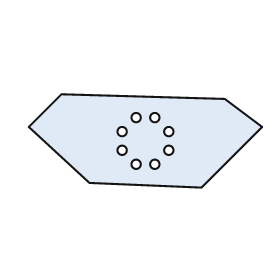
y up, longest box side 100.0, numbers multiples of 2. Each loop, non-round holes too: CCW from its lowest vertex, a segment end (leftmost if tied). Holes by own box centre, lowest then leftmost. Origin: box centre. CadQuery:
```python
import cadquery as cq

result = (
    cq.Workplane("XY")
    .moveTo(24.0, -20.0)
    .lineTo(50.0, 6.0)
    .lineTo(34.0, 18.0)
    .lineTo(-36.0, 20.0)
    .lineTo(-50.0, 6.0)
    .lineTo(-24.0, -18.0)
    .close()
    .moveTo(-4.0, -10.0)
    .circle(2.0)
    .moveTo(4.0, -10.0)
    .circle(2.0)
    .moveTo(-10.0, -4.0)
    .circle(2.0)
    .moveTo(10.0, -4.0)
    .circle(2.0)
    .moveTo(-10.0, 4.0)
    .circle(2.0)
    .moveTo(10.0, 4.0)
    .circle(2.0)
    .moveTo(-4.0, 10.0)
    .circle(2.0)
    .moveTo(4.0, 10.0)
    .circle(2.0)
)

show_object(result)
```